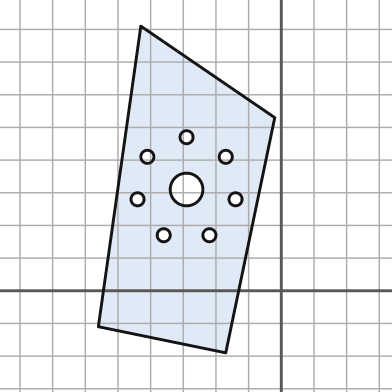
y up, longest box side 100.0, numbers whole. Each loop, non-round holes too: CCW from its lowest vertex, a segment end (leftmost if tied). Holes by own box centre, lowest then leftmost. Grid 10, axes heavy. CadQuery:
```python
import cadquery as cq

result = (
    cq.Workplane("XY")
    .moveTo(-17.0, -19.0)
    .lineTo(-2.0, 53.0)
    .lineTo(-43.0, 81.0)
    .lineTo(-56.0, -11.0)
    .close()
    .moveTo(-36.0, 17.0)
    .circle(2.0)
    .moveTo(-22.0, 17.0)
    .circle(2.0)
    .moveTo(-44.0, 28.0)
    .circle(2.0)
    .moveTo(-14.0, 28.0)
    .circle(2.0)
    .moveTo(-29.0, 31.0)
    .circle(5.0)
    .moveTo(-41.0, 41.0)
    .circle(2.0)
    .moveTo(-17.0, 41.0)
    .circle(2.0)
    .moveTo(-29.0, 47.0)
    .circle(2.0)
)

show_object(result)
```